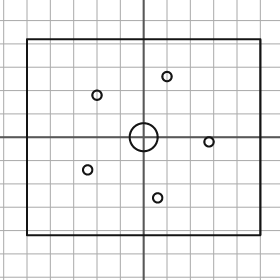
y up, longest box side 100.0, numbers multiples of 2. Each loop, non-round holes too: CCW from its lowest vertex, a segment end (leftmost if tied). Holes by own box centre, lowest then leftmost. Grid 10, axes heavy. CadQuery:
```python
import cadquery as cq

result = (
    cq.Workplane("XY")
    .moveTo(-50.0, -42.0)
    .lineTo(50.0, -42.0)
    .lineTo(50.0, 42.0)
    .lineTo(-50.0, 42.0)
    .close()
    .moveTo(6.0, -26.0)
    .circle(2.0)
    .moveTo(-24.0, -14.0)
    .circle(2.0)
    .moveTo(28.0, -2.0)
    .circle(2.0)
    .moveTo(0.0, 0.0)
    .circle(6.0)
    .moveTo(-20.0, 18.0)
    .circle(2.0)
    .moveTo(10.0, 26.0)
    .circle(2.0)
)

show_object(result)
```